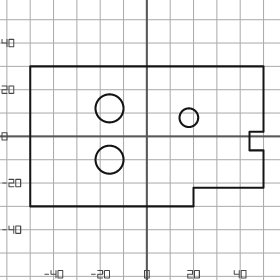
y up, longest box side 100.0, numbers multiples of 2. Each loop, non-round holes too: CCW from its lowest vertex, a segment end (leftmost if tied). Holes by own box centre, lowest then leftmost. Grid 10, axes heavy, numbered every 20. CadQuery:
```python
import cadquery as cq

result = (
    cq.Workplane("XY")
    .moveTo(-50.0, -30.0)
    .lineTo(20.0, -30.0)
    .lineTo(20.0, -22.0)
    .lineTo(50.0, -22.0)
    .lineTo(50.0, -6.0)
    .lineTo(44.0, -6.0)
    .lineTo(44.0, 2.0)
    .lineTo(50.0, 2.0)
    .lineTo(50.0, 30.0)
    .lineTo(-50.0, 30.0)
    .close()
    .moveTo(-16.0, -10.0)
    .circle(6.0)
    .moveTo(18.0, 8.0)
    .circle(4.0)
    .moveTo(-16.0, 12.0)
    .circle(6.0)
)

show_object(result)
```